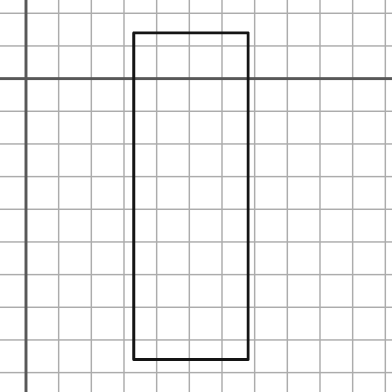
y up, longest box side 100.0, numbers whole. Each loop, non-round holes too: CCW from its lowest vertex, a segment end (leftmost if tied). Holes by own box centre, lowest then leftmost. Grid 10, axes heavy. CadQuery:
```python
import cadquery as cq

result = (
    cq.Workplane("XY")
    .moveTo(33.0, -86.0)
    .lineTo(68.0, -86.0)
    .lineTo(68.0, 14.0)
    .lineTo(33.0, 14.0)
    .close()
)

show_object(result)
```